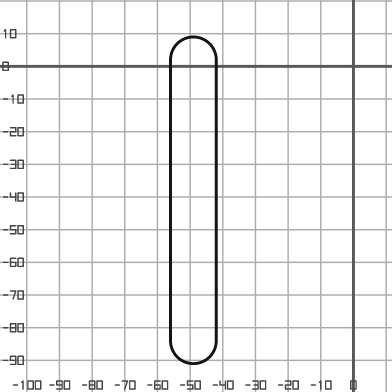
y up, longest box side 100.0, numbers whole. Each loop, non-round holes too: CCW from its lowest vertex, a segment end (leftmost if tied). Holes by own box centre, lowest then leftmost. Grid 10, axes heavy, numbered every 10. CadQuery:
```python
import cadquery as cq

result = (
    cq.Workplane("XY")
    .moveTo(-56.0, -84.0)
    .threePointArc((-49.0, -91.0), (-42.0, -84.0))
    .lineTo(-42.0, 2.0)
    .threePointArc((-49.0, 9.0), (-56.0, 2.0))
    .close()
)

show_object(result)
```